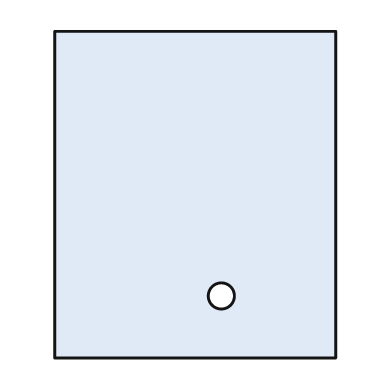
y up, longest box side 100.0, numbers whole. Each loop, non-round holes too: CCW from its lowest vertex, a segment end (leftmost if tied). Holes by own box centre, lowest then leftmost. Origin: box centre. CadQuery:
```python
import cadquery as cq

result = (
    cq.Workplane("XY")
    .moveTo(-43.0, -50.0)
    .lineTo(43.0, -50.0)
    .lineTo(43.0, 50.0)
    .lineTo(-43.0, 50.0)
    .close()
    .moveTo(8.0, -31.0)
    .circle(4.0)
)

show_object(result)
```